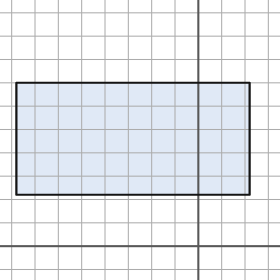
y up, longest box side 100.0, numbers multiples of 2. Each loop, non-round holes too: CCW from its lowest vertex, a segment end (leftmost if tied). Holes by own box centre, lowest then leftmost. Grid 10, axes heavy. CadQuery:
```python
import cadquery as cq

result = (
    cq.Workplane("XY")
    .moveTo(-78.0, 22.0)
    .lineTo(22.0, 22.0)
    .lineTo(22.0, 70.0)
    .lineTo(-78.0, 70.0)
    .close()
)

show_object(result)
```